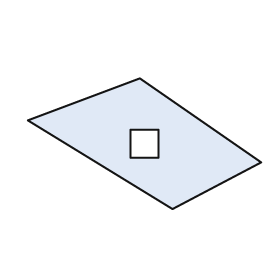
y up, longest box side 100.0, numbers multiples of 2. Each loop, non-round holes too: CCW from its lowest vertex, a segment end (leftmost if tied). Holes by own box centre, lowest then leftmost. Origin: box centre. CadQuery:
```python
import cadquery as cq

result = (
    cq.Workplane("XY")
    .moveTo(12.0, -28.0)
    .lineTo(50.0, -8.0)
    .lineTo(-2.0, 28.0)
    .lineTo(-50.0, 10.0)
    .close()
    .moveTo(-6.0, -6.0)
    .lineTo(6.0, -6.0)
    .lineTo(6.0, 6.0)
    .lineTo(-6.0, 6.0)
    .close()
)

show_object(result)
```